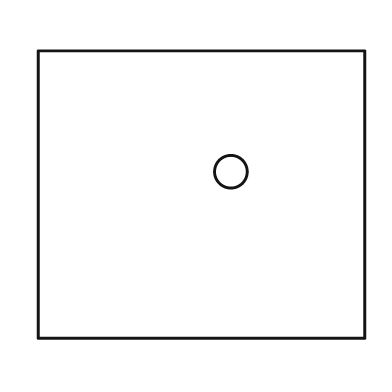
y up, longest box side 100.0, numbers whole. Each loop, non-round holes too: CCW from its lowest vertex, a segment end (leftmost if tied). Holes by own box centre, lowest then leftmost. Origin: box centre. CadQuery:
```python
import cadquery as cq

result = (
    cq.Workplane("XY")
    .moveTo(-50.0, -44.0)
    .lineTo(50.0, -44.0)
    .lineTo(50.0, 44.0)
    .lineTo(-50.0, 44.0)
    .close()
    .moveTo(9.0, 7.0)
    .circle(5.0)
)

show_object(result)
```